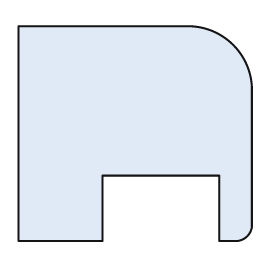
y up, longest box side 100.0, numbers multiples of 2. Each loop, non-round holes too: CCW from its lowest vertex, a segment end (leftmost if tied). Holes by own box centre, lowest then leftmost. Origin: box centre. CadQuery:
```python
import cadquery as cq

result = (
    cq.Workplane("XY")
    .moveTo(-50.0, -46.0)
    .lineTo(-14.0, -46.0)
    .lineTo(-14.0, -18.0)
    .lineTo(36.0, -18.0)
    .lineTo(36.0, -46.0)
    .lineTo(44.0, -46.0)
    .threePointArc((48.0, -44.0), (50.0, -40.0))
    .lineTo(50.0, 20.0)
    .threePointArc((42.0, 38.0), (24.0, 46.0))
    .lineTo(-50.0, 46.0)
    .close()
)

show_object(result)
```